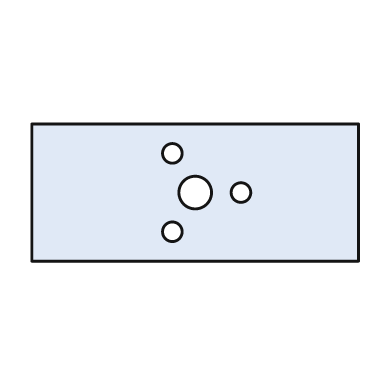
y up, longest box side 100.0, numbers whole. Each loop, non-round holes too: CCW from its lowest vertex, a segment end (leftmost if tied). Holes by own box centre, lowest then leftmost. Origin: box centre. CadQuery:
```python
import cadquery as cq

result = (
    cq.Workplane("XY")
    .moveTo(-50.0, -21.0)
    .lineTo(50.0, -21.0)
    .lineTo(50.0, 21.0)
    .lineTo(-50.0, 21.0)
    .close()
    .moveTo(-7.0, -12.0)
    .circle(3.0)
    .moveTo(0.0, 0.0)
    .circle(5.0)
    .moveTo(14.0, 0.0)
    .circle(3.0)
    .moveTo(-7.0, 12.0)
    .circle(3.0)
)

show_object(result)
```